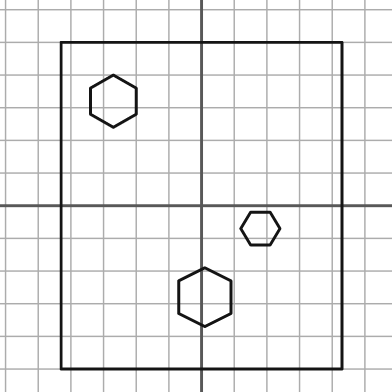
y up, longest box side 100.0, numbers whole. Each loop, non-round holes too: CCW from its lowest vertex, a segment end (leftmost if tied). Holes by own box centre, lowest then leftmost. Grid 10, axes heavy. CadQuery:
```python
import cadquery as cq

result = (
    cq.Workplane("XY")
    .moveTo(-43.0, -50.0)
    .lineTo(43.0, -50.0)
    .lineTo(43.0, 50.0)
    .lineTo(-43.0, 50.0)
    .close()
    .moveTo(1.0, -37.0)
    .lineTo(9.0, -33.0)
    .lineTo(9.0, -23.0)
    .lineTo(1.0, -19.0)
    .lineTo(-7.0, -23.0)
    .lineTo(-7.0, -33.0)
    .close()
    .moveTo(15.0, -12.0)
    .lineTo(21.0, -12.0)
    .lineTo(24.0, -7.0)
    .lineTo(21.0, -2.0)
    .lineTo(15.0, -2.0)
    .lineTo(12.0, -7.0)
    .close()
    .moveTo(-27.0, 24.0)
    .lineTo(-20.0, 28.0)
    .lineTo(-20.0, 36.0)
    .lineTo(-27.0, 40.0)
    .lineTo(-34.0, 36.0)
    .lineTo(-34.0, 28.0)
    .close()
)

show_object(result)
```